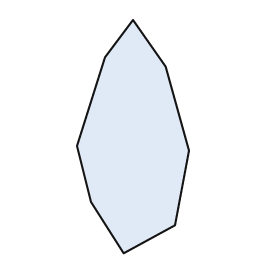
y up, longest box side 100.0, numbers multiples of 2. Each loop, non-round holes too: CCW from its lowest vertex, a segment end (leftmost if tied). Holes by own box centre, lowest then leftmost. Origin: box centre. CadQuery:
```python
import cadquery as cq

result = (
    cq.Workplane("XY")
    .moveTo(-4.0, -50.0)
    .lineTo(18.0, -38.0)
    .lineTo(24.0, -6.0)
    .lineTo(14.0, 30.0)
    .lineTo(0.0, 50.0)
    .lineTo(-12.0, 34.0)
    .lineTo(-24.0, -4.0)
    .lineTo(-18.0, -28.0)
    .close()
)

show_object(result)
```